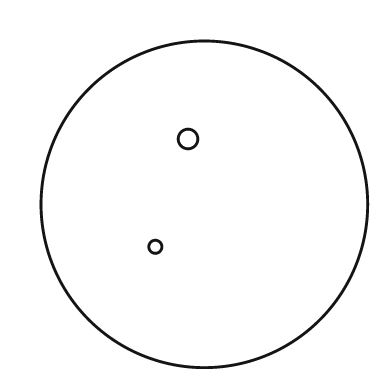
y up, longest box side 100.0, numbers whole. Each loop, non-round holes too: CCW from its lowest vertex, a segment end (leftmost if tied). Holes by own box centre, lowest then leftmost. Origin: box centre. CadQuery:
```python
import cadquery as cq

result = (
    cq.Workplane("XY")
    .moveTo(0.0, 0.0)
    .circle(50.0)
    .moveTo(-15.0, -13.0)
    .circle(2.0)
    .moveTo(-5.0, 20.0)
    .circle(3.0)
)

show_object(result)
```